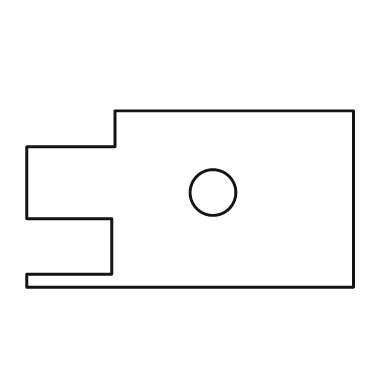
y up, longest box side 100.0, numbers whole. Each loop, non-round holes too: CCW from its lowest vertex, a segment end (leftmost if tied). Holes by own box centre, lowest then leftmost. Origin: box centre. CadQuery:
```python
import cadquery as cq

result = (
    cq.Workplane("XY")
    .moveTo(-50.0, -27.0)
    .lineTo(50.0, -27.0)
    .lineTo(50.0, 27.0)
    .lineTo(-23.0, 27.0)
    .lineTo(-23.0, 16.0)
    .lineTo(-50.0, 16.0)
    .lineTo(-50.0, -6.0)
    .lineTo(-24.0, -6.0)
    .lineTo(-24.0, -23.0)
    .lineTo(-50.0, -23.0)
    .close()
    .moveTo(7.0, 2.0)
    .circle(7.0)
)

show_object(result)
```